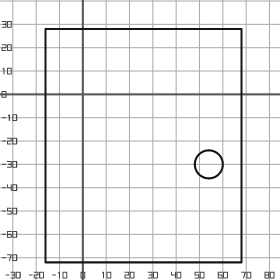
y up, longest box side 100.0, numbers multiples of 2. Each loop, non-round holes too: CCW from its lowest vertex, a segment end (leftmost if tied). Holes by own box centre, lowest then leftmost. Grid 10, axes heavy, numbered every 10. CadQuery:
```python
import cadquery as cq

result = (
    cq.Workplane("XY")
    .moveTo(-16.0, -72.0)
    .lineTo(68.0, -72.0)
    .lineTo(68.0, 28.0)
    .lineTo(-16.0, 28.0)
    .close()
    .moveTo(54.0, -30.0)
    .circle(6.0)
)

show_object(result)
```